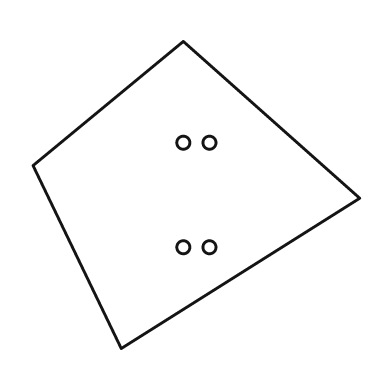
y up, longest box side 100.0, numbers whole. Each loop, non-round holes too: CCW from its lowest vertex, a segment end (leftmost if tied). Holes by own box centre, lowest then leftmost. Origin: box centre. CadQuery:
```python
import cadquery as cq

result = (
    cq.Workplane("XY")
    .moveTo(-23.0, -47.0)
    .lineTo(50.0, -1.0)
    .lineTo(-4.0, 47.0)
    .lineTo(-50.0, 9.0)
    .close()
    .moveTo(-4.0, -16.0)
    .circle(2.0)
    .moveTo(4.0, -16.0)
    .circle(2.0)
    .moveTo(-4.0, 16.0)
    .circle(2.0)
    .moveTo(4.0, 16.0)
    .circle(2.0)
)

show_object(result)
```